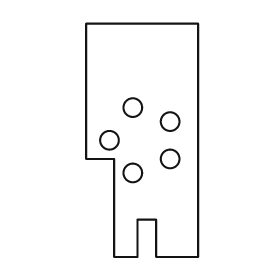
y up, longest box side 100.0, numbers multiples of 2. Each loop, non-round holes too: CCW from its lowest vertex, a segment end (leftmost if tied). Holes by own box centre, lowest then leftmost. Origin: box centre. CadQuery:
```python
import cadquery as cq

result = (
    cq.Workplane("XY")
    .moveTo(-12.0, -50.0)
    .lineTo(-2.0, -50.0)
    .lineTo(-2.0, -34.0)
    .lineTo(6.0, -34.0)
    .lineTo(6.0, -50.0)
    .lineTo(24.0, -50.0)
    .lineTo(24.0, 50.0)
    .lineTo(-24.0, 50.0)
    .lineTo(-24.0, -8.0)
    .lineTo(-12.0, -8.0)
    .close()
    .moveTo(-4.0, -14.0)
    .circle(4.0)
    .moveTo(12.0, -8.0)
    .circle(4.0)
    .moveTo(-14.0, 0.0)
    .circle(4.0)
    .moveTo(12.0, 8.0)
    .circle(4.0)
    .moveTo(-4.0, 14.0)
    .circle(4.0)
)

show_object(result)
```